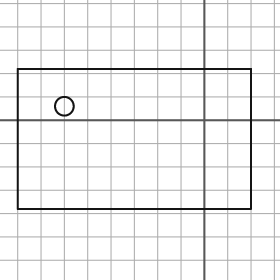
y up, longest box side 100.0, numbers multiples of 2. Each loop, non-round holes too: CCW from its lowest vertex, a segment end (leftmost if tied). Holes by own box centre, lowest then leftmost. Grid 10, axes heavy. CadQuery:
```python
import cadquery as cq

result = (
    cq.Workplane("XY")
    .moveTo(-80.0, -38.0)
    .lineTo(20.0, -38.0)
    .lineTo(20.0, 22.0)
    .lineTo(-80.0, 22.0)
    .close()
    .moveTo(-60.0, 6.0)
    .circle(4.0)
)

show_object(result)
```